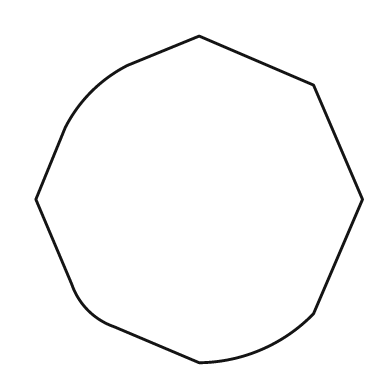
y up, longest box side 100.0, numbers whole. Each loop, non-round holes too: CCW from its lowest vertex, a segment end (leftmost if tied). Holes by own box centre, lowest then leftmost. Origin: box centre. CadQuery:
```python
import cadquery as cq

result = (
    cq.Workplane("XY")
    .moveTo(0.0, -50.0)
    .threePointArc((19.0, -46.0), (35.0, -35.0))
    .lineTo(50.0, 0.0)
    .lineTo(35.0, 35.0)
    .lineTo(0.0, 50.0)
    .lineTo(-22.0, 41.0)
    .threePointArc((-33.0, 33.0), (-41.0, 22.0))
    .lineTo(-50.0, 0.0)
    .lineTo(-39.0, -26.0)
    .threePointArc((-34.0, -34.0), (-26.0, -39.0))
    .close()
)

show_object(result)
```